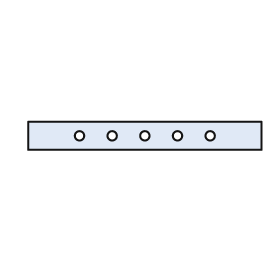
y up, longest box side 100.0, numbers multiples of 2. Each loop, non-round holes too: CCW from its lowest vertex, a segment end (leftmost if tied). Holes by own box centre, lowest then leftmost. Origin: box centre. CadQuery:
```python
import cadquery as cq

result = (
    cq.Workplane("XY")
    .moveTo(-50.0, -6.0)
    .lineTo(50.0, -6.0)
    .lineTo(50.0, 6.0)
    .lineTo(-50.0, 6.0)
    .close()
    .moveTo(-28.0, 0.0)
    .circle(2.0)
    .moveTo(-14.0, 0.0)
    .circle(2.0)
    .moveTo(0.0, 0.0)
    .circle(2.0)
    .moveTo(14.0, 0.0)
    .circle(2.0)
    .moveTo(28.0, 0.0)
    .circle(2.0)
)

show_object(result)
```